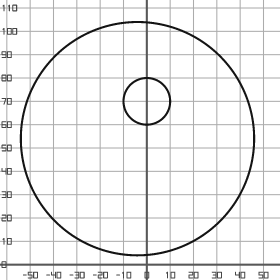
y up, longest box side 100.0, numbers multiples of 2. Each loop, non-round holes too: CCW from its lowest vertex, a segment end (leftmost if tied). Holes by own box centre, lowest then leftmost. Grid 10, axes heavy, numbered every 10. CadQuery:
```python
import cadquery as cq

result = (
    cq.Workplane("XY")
    .moveTo(-4.0, 54.0)
    .circle(50.0)
    .moveTo(0.0, 70.0)
    .circle(10.0)
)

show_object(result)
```